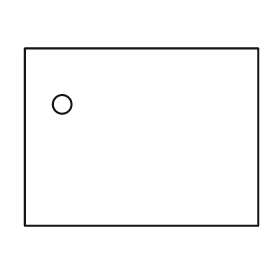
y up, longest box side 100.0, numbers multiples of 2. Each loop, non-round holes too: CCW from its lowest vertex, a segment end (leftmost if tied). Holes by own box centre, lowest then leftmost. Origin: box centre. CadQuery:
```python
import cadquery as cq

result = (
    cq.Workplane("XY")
    .moveTo(-50.0, -38.0)
    .lineTo(50.0, -38.0)
    .lineTo(50.0, 38.0)
    .lineTo(-50.0, 38.0)
    .close()
    .moveTo(-34.0, 14.0)
    .circle(4.0)
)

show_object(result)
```